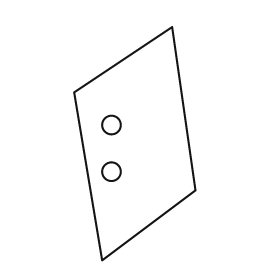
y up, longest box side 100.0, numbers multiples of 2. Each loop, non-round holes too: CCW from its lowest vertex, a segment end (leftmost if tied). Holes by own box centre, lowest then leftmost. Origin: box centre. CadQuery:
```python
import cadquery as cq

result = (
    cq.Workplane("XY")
    .moveTo(-14.0, -50.0)
    .lineTo(26.0, -20.0)
    .lineTo(16.0, 50.0)
    .lineTo(-26.0, 22.0)
    .close()
    .moveTo(-10.0, -12.0)
    .circle(4.0)
    .moveTo(-10.0, 8.0)
    .circle(4.0)
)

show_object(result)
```